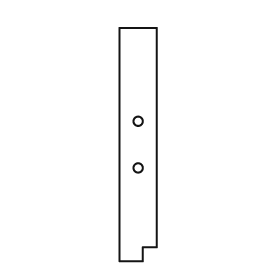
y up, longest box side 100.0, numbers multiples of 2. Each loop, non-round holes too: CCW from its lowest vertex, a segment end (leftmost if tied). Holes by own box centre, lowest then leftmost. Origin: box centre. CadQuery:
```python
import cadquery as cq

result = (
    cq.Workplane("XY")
    .moveTo(-8.0, -50.0)
    .lineTo(2.0, -50.0)
    .lineTo(2.0, -44.0)
    .lineTo(8.0, -44.0)
    .lineTo(8.0, 50.0)
    .lineTo(-8.0, 50.0)
    .close()
    .moveTo(0.0, -10.0)
    .circle(2.0)
    .moveTo(0.0, 10.0)
    .circle(2.0)
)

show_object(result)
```